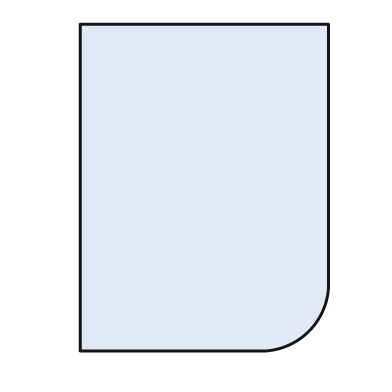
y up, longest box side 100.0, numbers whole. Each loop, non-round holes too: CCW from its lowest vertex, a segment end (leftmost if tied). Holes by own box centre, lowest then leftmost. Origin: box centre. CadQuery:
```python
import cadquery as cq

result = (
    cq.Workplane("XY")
    .moveTo(-38.0, -50.0)
    .lineTo(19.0, -50.0)
    .threePointArc((32.0, -44.0), (38.0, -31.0))
    .lineTo(38.0, 50.0)
    .lineTo(-38.0, 50.0)
    .close()
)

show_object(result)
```